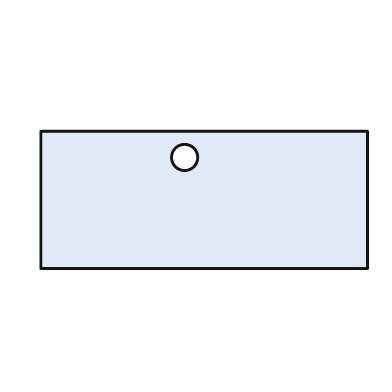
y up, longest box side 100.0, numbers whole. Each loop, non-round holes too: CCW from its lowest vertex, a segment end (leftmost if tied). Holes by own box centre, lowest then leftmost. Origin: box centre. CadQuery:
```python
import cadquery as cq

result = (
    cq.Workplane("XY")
    .moveTo(-50.0, -21.0)
    .lineTo(50.0, -21.0)
    .lineTo(50.0, 21.0)
    .lineTo(-50.0, 21.0)
    .close()
    .moveTo(-6.0, 13.0)
    .circle(4.0)
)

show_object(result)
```